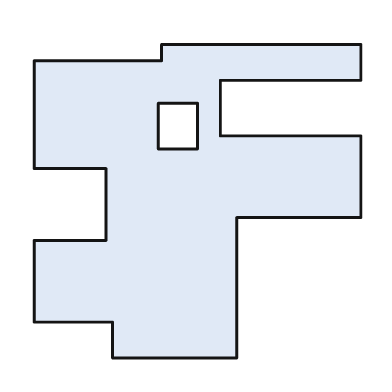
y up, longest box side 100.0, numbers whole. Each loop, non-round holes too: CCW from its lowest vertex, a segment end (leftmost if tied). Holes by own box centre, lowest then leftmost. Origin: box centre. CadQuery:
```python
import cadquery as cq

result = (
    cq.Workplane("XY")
    .moveTo(-26.0, -48.0)
    .lineTo(12.0, -48.0)
    .lineTo(12.0, -5.0)
    .lineTo(50.0, -5.0)
    .lineTo(50.0, 20.0)
    .lineTo(7.0, 20.0)
    .lineTo(7.0, 37.0)
    .lineTo(50.0, 37.0)
    .lineTo(50.0, 48.0)
    .lineTo(-11.0, 48.0)
    .lineTo(-11.0, 43.0)
    .lineTo(-50.0, 43.0)
    .lineTo(-50.0, 10.0)
    .lineTo(-28.0, 10.0)
    .lineTo(-28.0, -12.0)
    .lineTo(-50.0, -12.0)
    .lineTo(-50.0, -37.0)
    .lineTo(-26.0, -37.0)
    .close()
    .moveTo(-12.0, 16.0)
    .lineTo(0.0, 16.0)
    .lineTo(0.0, 30.0)
    .lineTo(-12.0, 30.0)
    .close()
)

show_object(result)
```